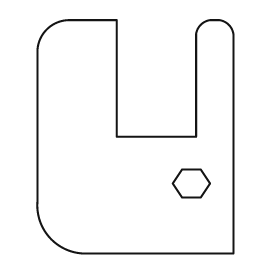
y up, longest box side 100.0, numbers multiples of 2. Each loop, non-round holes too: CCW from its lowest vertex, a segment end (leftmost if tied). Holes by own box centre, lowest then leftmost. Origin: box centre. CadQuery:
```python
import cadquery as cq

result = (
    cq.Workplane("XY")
    .moveTo(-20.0, -50.0)
    .lineTo(42.0, -50.0)
    .lineTo(42.0, 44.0)
    .threePointArc((40.0, 48.0), (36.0, 50.0))
    .lineTo(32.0, 50.0)
    .threePointArc((28.0, 48.0), (26.0, 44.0))
    .lineTo(26.0, 0.0)
    .lineTo(-8.0, 0.0)
    .lineTo(-8.0, 50.0)
    .lineTo(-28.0, 50.0)
    .threePointArc((-38.0, 46.0), (-42.0, 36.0))
    .lineTo(-42.0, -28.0)
    .threePointArc((-36.0, -44.0), (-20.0, -50.0))
    .close()
    .moveTo(20.0, -26.0)
    .lineTo(28.0, -26.0)
    .lineTo(32.0, -20.0)
    .lineTo(28.0, -14.0)
    .lineTo(20.0, -14.0)
    .lineTo(16.0, -20.0)
    .close()
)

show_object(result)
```